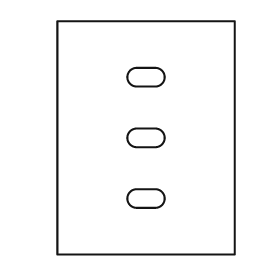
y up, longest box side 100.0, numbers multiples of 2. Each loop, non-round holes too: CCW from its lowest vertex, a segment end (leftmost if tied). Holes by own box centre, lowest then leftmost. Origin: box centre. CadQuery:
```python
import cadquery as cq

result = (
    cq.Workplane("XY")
    .moveTo(-38.0, -50.0)
    .lineTo(38.0, -50.0)
    .lineTo(38.0, 50.0)
    .lineTo(-38.0, 50.0)
    .close()
    .moveTo(-4.0, -30.0)
    .lineTo(4.0, -30.0)
    .threePointArc((8.0, -26.0), (4.0, -22.0))
    .lineTo(-4.0, -22.0)
    .threePointArc((-8.0, -26.0), (-4.0, -30.0))
    .close()
    .moveTo(-4.0, -4.0)
    .lineTo(4.0, -4.0)
    .threePointArc((8.0, 0.0), (4.0, 4.0))
    .lineTo(-4.0, 4.0)
    .threePointArc((-8.0, 0.0), (-4.0, -4.0))
    .close()
    .moveTo(-4.0, 22.0)
    .lineTo(4.0, 22.0)
    .threePointArc((8.0, 26.0), (4.0, 30.0))
    .lineTo(-4.0, 30.0)
    .threePointArc((-8.0, 26.0), (-4.0, 22.0))
    .close()
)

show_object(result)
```